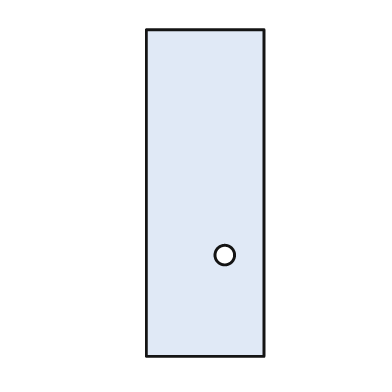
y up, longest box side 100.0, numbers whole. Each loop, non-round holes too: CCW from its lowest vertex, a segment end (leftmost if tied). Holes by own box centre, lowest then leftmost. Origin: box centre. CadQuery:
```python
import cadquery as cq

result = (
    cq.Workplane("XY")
    .moveTo(-18.0, -50.0)
    .lineTo(18.0, -50.0)
    .lineTo(18.0, 50.0)
    .lineTo(-18.0, 50.0)
    .close()
    .moveTo(6.0, -19.0)
    .circle(3.0)
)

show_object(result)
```